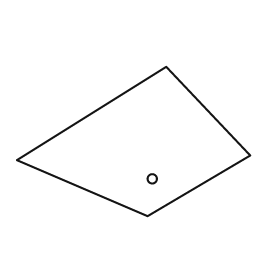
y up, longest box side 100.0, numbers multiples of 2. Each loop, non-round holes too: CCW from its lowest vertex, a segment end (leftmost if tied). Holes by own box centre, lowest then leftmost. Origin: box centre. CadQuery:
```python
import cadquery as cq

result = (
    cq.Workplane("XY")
    .moveTo(6.0, -32.0)
    .lineTo(50.0, -6.0)
    .lineTo(14.0, 32.0)
    .lineTo(-50.0, -8.0)
    .close()
    .moveTo(8.0, -16.0)
    .circle(2.0)
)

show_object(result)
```